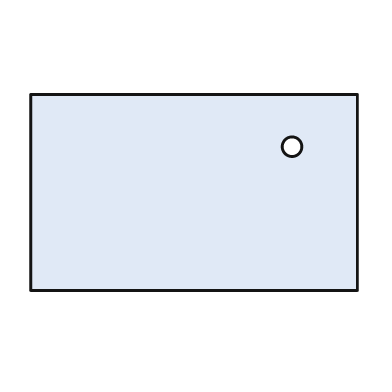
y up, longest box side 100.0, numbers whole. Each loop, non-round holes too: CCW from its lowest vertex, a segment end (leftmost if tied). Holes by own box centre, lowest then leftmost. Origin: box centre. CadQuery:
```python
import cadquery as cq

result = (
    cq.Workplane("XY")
    .moveTo(-50.0, -30.0)
    .lineTo(50.0, -30.0)
    .lineTo(50.0, 30.0)
    .lineTo(-50.0, 30.0)
    .close()
    .moveTo(30.0, 14.0)
    .circle(3.0)
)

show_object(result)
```